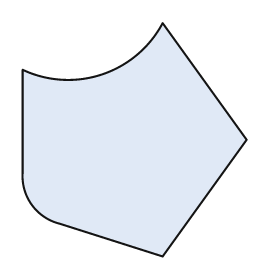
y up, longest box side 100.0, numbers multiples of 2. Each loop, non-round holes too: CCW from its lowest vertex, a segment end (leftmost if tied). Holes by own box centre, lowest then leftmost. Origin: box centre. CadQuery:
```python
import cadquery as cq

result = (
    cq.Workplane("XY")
    .moveTo(12.0, -50.0)
    .lineTo(48.0, 0.0)
    .lineTo(12.0, 50.0)
    .threePointArc((-14.0, 28.0), (-48.0, 30.0))
    .lineTo(-48.0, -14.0)
    .threePointArc((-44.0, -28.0), (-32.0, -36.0))
    .close()
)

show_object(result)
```